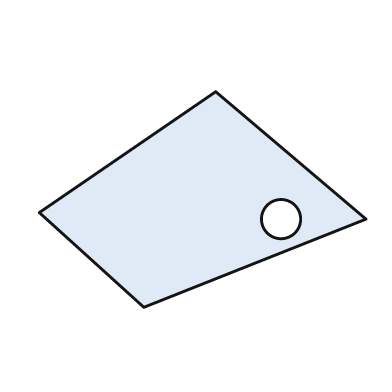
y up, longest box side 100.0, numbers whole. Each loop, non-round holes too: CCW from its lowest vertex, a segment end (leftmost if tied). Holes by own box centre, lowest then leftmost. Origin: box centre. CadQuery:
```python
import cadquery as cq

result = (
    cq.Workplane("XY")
    .moveTo(-18.0, -33.0)
    .lineTo(50.0, -6.0)
    .lineTo(4.0, 33.0)
    .lineTo(-50.0, -4.0)
    .close()
    .moveTo(24.0, -6.0)
    .circle(6.0)
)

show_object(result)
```